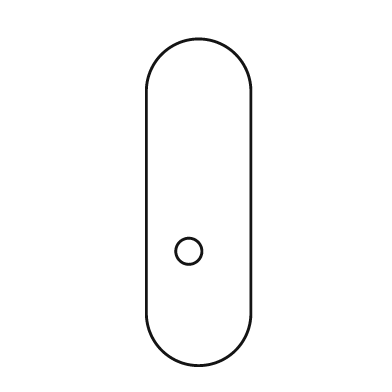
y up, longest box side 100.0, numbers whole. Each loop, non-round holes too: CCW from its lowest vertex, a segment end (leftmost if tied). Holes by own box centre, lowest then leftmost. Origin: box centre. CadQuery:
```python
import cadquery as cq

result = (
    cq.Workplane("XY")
    .moveTo(-16.0, -34.0)
    .threePointArc((0.0, -50.0), (16.0, -34.0))
    .lineTo(16.0, 34.0)
    .threePointArc((0.0, 50.0), (-16.0, 34.0))
    .close()
    .moveTo(-3.0, -15.0)
    .circle(4.0)
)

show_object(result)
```